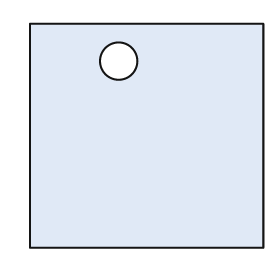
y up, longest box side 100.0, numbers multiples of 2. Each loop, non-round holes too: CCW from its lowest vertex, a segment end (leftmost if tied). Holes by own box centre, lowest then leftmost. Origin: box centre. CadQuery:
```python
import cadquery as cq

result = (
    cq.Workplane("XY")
    .moveTo(-50.0, -48.0)
    .lineTo(50.0, -48.0)
    .lineTo(50.0, 48.0)
    .lineTo(-50.0, 48.0)
    .close()
    .moveTo(-12.0, 32.0)
    .circle(8.0)
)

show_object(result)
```